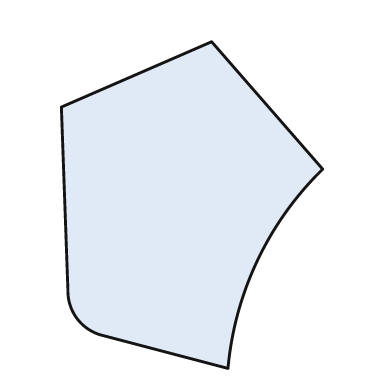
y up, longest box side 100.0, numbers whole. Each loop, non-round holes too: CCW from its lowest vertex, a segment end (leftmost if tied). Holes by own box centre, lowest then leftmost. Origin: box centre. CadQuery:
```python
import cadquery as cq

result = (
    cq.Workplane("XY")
    .moveTo(11.0, -50.0)
    .threePointArc((20.0, -17.0), (40.0, 11.0))
    .lineTo(6.0, 50.0)
    .lineTo(-40.0, 30.0)
    .lineTo(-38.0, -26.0)
    .threePointArc((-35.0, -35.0), (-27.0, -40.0))
    .close()
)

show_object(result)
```